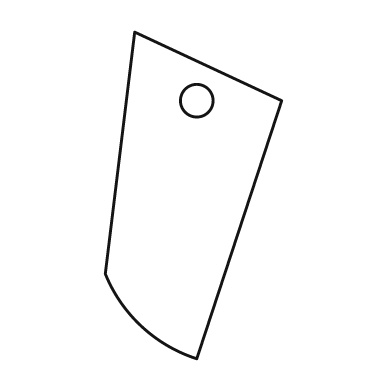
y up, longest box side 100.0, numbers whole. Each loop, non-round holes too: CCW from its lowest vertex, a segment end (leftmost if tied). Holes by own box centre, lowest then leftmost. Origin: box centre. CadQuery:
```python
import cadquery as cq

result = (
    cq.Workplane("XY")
    .moveTo(1.0, -50.0)
    .lineTo(27.0, 29.0)
    .lineTo(-18.0, 50.0)
    .lineTo(-27.0, -24.0)
    .threePointArc((-16.0, -40.0), (1.0, -50.0))
    .close()
    .moveTo(1.0, 29.0)
    .circle(5.0)
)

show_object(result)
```